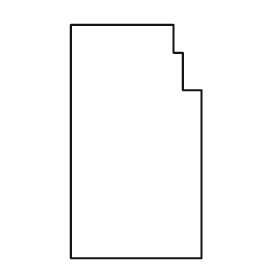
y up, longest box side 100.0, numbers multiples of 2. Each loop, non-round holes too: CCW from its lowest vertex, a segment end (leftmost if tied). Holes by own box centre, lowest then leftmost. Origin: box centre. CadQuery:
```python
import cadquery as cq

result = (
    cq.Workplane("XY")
    .moveTo(-28.0, -50.0)
    .lineTo(28.0, -50.0)
    .lineTo(28.0, 22.0)
    .lineTo(20.0, 22.0)
    .lineTo(20.0, 38.0)
    .lineTo(16.0, 38.0)
    .lineTo(16.0, 50.0)
    .lineTo(-28.0, 50.0)
    .close()
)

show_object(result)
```